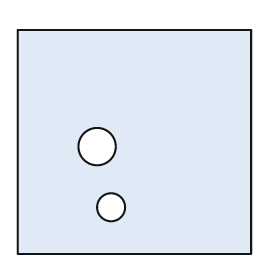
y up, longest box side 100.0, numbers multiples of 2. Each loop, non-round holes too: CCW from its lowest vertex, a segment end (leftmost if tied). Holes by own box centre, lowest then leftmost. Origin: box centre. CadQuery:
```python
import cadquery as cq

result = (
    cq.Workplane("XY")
    .moveTo(-50.0, -48.0)
    .lineTo(50.0, -48.0)
    .lineTo(50.0, 48.0)
    .lineTo(-50.0, 48.0)
    .close()
    .moveTo(-10.0, -28.0)
    .circle(6.0)
    .moveTo(-16.0, -2.0)
    .circle(8.0)
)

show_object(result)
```